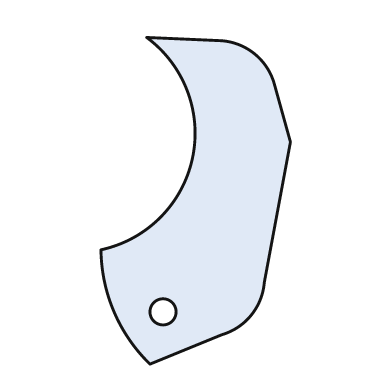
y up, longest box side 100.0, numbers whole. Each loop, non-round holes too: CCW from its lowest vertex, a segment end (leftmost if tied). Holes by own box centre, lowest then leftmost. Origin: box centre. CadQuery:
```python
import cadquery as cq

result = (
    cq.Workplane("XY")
    .moveTo(-14.0, -50.0)
    .lineTo(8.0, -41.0)
    .threePointArc((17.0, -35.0), (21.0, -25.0))
    .lineTo(29.0, 18.0)
    .lineTo(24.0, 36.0)
    .threePointArc((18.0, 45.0), (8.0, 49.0))
    .lineTo(-15.0, 50.0)
    .threePointArc((-1.0, 13.0), (-29.0, -15.0))
    .threePointArc((-25.0, -34.0), (-14.0, -50.0))
    .close()
    .moveTo(-10.0, -34.0)
    .circle(4.0)
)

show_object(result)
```